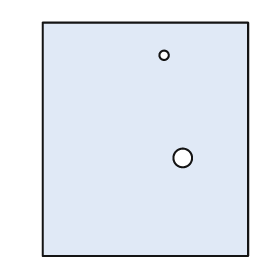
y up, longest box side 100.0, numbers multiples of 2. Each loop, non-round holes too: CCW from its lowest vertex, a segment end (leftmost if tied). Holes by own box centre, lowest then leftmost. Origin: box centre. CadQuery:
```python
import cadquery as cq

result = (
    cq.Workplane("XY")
    .moveTo(-44.0, -50.0)
    .lineTo(44.0, -50.0)
    .lineTo(44.0, 50.0)
    .lineTo(-44.0, 50.0)
    .close()
    .moveTo(16.0, -8.0)
    .circle(4.0)
    .moveTo(8.0, 36.0)
    .circle(2.0)
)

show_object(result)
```